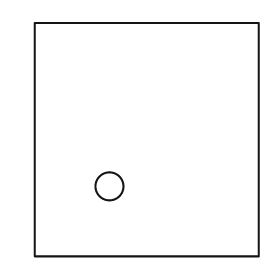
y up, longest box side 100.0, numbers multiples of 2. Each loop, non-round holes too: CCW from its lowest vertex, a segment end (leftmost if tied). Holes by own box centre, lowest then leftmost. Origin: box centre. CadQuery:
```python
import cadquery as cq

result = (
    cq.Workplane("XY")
    .moveTo(-48.0, -50.0)
    .lineTo(48.0, -50.0)
    .lineTo(48.0, 50.0)
    .lineTo(-48.0, 50.0)
    .close()
    .moveTo(-16.0, -20.0)
    .circle(6.0)
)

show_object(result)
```